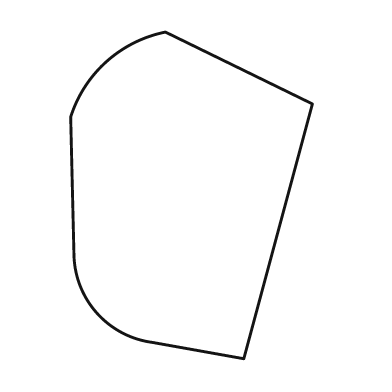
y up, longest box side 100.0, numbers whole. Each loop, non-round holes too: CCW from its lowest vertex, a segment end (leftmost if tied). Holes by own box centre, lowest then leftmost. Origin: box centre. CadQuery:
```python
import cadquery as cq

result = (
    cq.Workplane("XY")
    .moveTo(16.0, -50.0)
    .lineTo(37.0, 28.0)
    .lineTo(-8.0, 50.0)
    .threePointArc((-26.0, 41.0), (-37.0, 24.0))
    .lineTo(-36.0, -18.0)
    .threePointArc((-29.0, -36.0), (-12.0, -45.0))
    .close()
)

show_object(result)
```